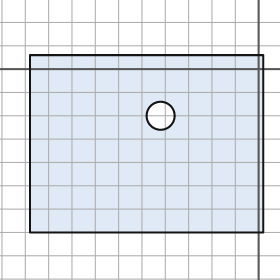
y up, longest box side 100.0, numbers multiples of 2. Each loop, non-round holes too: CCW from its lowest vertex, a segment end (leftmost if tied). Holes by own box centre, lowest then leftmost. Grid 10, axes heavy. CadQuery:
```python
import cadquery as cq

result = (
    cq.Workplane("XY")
    .moveTo(-98.0, -70.0)
    .lineTo(2.0, -70.0)
    .lineTo(2.0, 6.0)
    .lineTo(-98.0, 6.0)
    .close()
    .moveTo(-42.0, -20.0)
    .circle(6.0)
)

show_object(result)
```